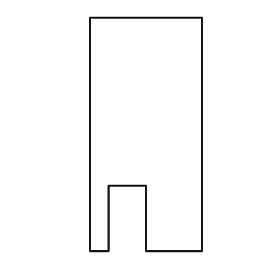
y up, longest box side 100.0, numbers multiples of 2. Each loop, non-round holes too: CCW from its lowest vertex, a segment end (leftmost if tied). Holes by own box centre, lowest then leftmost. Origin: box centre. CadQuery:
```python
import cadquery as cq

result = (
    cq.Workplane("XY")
    .moveTo(-24.0, -50.0)
    .lineTo(-16.0, -50.0)
    .lineTo(-16.0, -22.0)
    .lineTo(0.0, -22.0)
    .lineTo(0.0, -50.0)
    .lineTo(24.0, -50.0)
    .lineTo(24.0, 50.0)
    .lineTo(-24.0, 50.0)
    .close()
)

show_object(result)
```